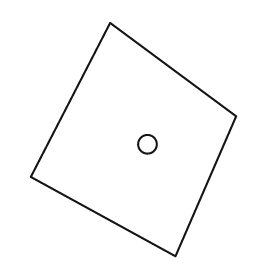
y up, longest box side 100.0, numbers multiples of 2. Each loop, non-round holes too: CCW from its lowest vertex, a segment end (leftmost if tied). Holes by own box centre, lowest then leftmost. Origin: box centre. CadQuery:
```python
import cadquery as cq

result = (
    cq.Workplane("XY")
    .moveTo(18.0, -50.0)
    .lineTo(44.0, 10.0)
    .lineTo(-10.0, 50.0)
    .lineTo(-44.0, -16.0)
    .close()
    .moveTo(6.0, -2.0)
    .circle(4.0)
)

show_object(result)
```